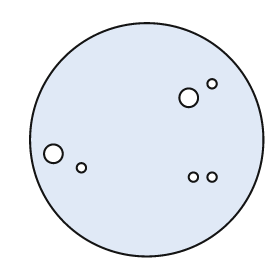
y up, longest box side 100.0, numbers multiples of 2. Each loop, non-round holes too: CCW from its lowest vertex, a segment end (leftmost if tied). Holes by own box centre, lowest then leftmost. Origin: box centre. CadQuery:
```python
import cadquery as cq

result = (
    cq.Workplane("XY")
    .moveTo(0.0, 0.0)
    .circle(50.0)
    .moveTo(20.0, -16.0)
    .circle(2.0)
    .moveTo(28.0, -16.0)
    .circle(2.0)
    .moveTo(-28.0, -12.0)
    .circle(2.0)
    .moveTo(-40.0, -6.0)
    .circle(4.0)
    .moveTo(18.0, 18.0)
    .circle(4.0)
    .moveTo(28.0, 24.0)
    .circle(2.0)
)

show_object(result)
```